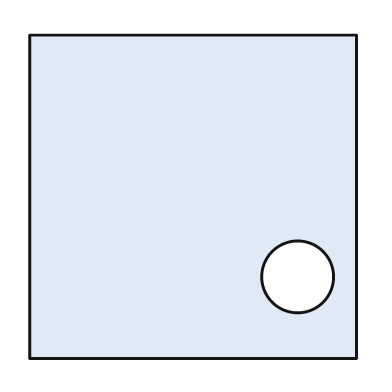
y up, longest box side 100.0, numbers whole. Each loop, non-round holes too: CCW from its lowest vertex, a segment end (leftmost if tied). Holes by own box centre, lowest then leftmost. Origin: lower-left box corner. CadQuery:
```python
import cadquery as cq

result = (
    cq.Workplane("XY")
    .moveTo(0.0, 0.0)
    .lineTo(100.0, 0.0)
    .lineTo(100.0, 99.0)
    .lineTo(0.0, 99.0)
    .close()
    .moveTo(82.0, 25.0)
    .circle(11.0)
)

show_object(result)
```